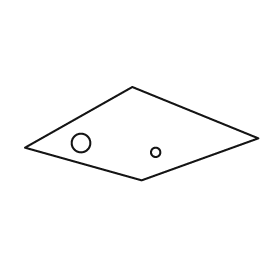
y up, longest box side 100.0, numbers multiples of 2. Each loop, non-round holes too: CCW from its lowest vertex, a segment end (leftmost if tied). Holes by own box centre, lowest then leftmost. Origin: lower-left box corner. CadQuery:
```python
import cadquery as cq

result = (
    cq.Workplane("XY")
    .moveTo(50.0, 0.0)
    .lineTo(100.0, 18.0)
    .lineTo(46.0, 40.0)
    .lineTo(0.0, 14.0)
    .close()
    .moveTo(56.0, 12.0)
    .circle(2.0)
    .moveTo(24.0, 16.0)
    .circle(4.0)
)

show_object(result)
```